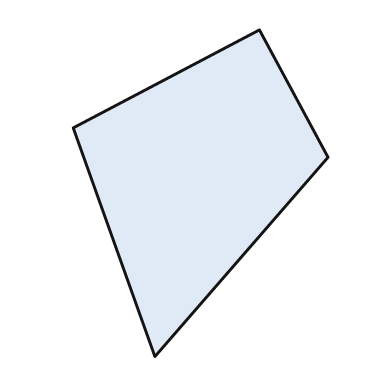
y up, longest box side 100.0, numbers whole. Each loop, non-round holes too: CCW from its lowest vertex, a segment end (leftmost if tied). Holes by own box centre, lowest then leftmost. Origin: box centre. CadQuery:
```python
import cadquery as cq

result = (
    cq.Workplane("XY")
    .moveTo(-14.0, -50.0)
    .lineTo(39.0, 11.0)
    .lineTo(18.0, 50.0)
    .lineTo(-39.0, 20.0)
    .close()
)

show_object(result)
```